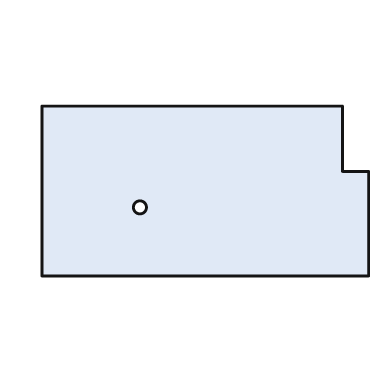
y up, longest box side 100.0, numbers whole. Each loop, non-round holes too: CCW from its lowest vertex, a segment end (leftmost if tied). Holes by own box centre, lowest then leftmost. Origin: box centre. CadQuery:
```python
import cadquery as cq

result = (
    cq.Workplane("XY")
    .moveTo(-50.0, -26.0)
    .lineTo(50.0, -26.0)
    .lineTo(50.0, 6.0)
    .lineTo(42.0, 6.0)
    .lineTo(42.0, 26.0)
    .lineTo(-50.0, 26.0)
    .close()
    .moveTo(-20.0, -5.0)
    .circle(2.0)
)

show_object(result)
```